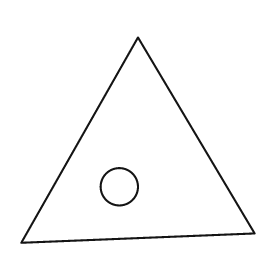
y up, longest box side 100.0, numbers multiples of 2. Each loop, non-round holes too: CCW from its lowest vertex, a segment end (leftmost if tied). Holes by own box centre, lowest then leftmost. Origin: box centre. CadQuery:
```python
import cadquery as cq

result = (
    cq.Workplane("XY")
    .moveTo(-50.0, -44.0)
    .lineTo(50.0, -40.0)
    .lineTo(0.0, 44.0)
    .close()
    .moveTo(-8.0, -20.0)
    .circle(8.0)
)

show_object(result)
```